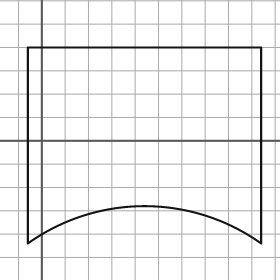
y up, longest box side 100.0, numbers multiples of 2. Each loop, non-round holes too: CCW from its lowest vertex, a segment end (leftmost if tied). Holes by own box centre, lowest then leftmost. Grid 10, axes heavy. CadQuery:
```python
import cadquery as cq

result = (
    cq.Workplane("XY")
    .moveTo(-6.0, -44.0)
    .threePointArc((44.0, -28.0), (94.0, -44.0))
    .lineTo(94.0, 40.0)
    .lineTo(-6.0, 40.0)
    .close()
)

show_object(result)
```